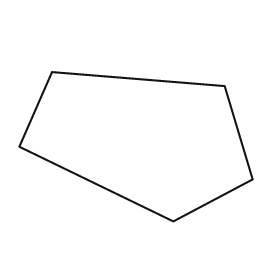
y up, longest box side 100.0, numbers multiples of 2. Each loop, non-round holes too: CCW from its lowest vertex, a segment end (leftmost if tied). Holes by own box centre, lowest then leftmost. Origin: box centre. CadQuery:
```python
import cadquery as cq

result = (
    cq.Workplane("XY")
    .moveTo(16.0, -32.0)
    .lineTo(50.0, -14.0)
    .lineTo(38.0, 26.0)
    .lineTo(-36.0, 32.0)
    .lineTo(-50.0, 0.0)
    .close()
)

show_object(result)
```